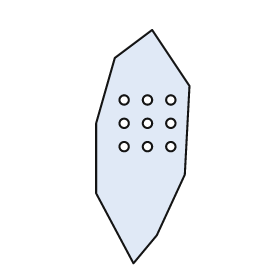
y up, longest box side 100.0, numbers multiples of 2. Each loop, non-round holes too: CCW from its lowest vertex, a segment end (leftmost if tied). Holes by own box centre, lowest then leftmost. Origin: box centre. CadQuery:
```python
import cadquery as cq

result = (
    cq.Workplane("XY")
    .moveTo(-4.0, -50.0)
    .lineTo(6.0, -38.0)
    .lineTo(18.0, -12.0)
    .lineTo(20.0, 26.0)
    .lineTo(4.0, 50.0)
    .lineTo(-12.0, 38.0)
    .lineTo(-20.0, 10.0)
    .lineTo(-20.0, -20.0)
    .close()
    .moveTo(-8.0, 0.0)
    .circle(2.0)
    .moveTo(2.0, 0.0)
    .circle(2.0)
    .moveTo(12.0, 0.0)
    .circle(2.0)
    .moveTo(-8.0, 10.0)
    .circle(2.0)
    .moveTo(2.0, 10.0)
    .circle(2.0)
    .moveTo(12.0, 10.0)
    .circle(2.0)
    .moveTo(-8.0, 20.0)
    .circle(2.0)
    .moveTo(2.0, 20.0)
    .circle(2.0)
    .moveTo(12.0, 20.0)
    .circle(2.0)
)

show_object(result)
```